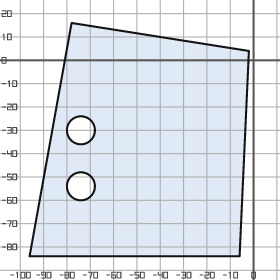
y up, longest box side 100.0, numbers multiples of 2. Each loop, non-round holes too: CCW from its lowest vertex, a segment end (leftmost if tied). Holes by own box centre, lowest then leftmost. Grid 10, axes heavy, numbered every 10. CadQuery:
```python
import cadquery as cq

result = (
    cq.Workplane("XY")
    .moveTo(-96.0, -84.0)
    .lineTo(-6.0, -84.0)
    .lineTo(-2.0, 4.0)
    .lineTo(-78.0, 16.0)
    .close()
    .moveTo(-74.0, -54.0)
    .circle(6.0)
    .moveTo(-74.0, -30.0)
    .circle(6.0)
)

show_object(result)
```